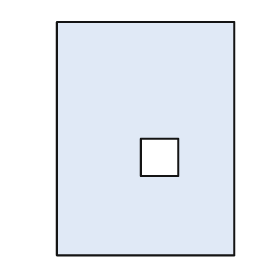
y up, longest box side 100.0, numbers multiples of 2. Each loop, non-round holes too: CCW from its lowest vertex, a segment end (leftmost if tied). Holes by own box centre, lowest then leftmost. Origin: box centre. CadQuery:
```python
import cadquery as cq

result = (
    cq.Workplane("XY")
    .moveTo(-38.0, -50.0)
    .lineTo(38.0, -50.0)
    .lineTo(38.0, 50.0)
    .lineTo(-38.0, 50.0)
    .close()
    .moveTo(-2.0, -16.0)
    .lineTo(14.0, -16.0)
    .lineTo(14.0, 0.0)
    .lineTo(-2.0, 0.0)
    .close()
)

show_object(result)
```